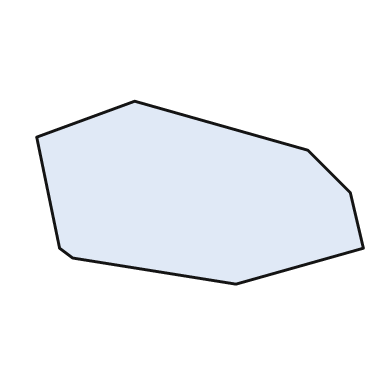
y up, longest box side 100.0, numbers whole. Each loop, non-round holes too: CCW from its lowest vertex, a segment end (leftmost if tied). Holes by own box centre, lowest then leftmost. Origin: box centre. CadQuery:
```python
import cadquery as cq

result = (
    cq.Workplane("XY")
    .moveTo(11.0, -28.0)
    .lineTo(50.0, -17.0)
    .lineTo(46.0, 0.0)
    .lineTo(33.0, 13.0)
    .lineTo(-20.0, 28.0)
    .lineTo(-50.0, 17.0)
    .lineTo(-43.0, -17.0)
    .lineTo(-39.0, -20.0)
    .close()
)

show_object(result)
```